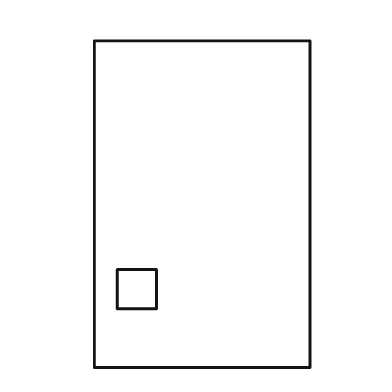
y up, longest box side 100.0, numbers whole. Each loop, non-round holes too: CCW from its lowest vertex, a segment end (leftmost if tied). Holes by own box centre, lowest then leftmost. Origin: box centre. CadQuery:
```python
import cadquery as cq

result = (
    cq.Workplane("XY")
    .moveTo(-33.0, -50.0)
    .lineTo(33.0, -50.0)
    .lineTo(33.0, 50.0)
    .lineTo(-33.0, 50.0)
    .close()
    .moveTo(-26.0, -32.0)
    .lineTo(-14.0, -32.0)
    .lineTo(-14.0, -20.0)
    .lineTo(-26.0, -20.0)
    .close()
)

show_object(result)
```